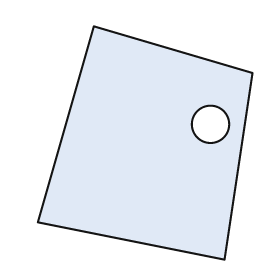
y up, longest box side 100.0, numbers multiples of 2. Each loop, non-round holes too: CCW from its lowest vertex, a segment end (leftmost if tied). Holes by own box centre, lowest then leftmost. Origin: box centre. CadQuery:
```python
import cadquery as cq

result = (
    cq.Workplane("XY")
    .moveTo(34.0, -50.0)
    .lineTo(46.0, 30.0)
    .lineTo(-22.0, 50.0)
    .lineTo(-46.0, -34.0)
    .close()
    .moveTo(28.0, 8.0)
    .circle(8.0)
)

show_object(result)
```